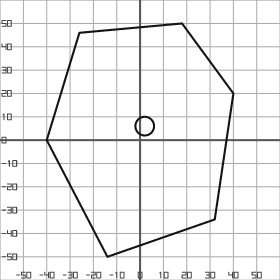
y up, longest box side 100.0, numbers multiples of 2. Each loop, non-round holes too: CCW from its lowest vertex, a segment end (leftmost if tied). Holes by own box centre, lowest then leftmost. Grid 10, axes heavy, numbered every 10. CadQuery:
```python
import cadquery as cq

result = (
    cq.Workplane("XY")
    .moveTo(-14.0, -50.0)
    .lineTo(32.0, -34.0)
    .lineTo(40.0, 20.0)
    .lineTo(18.0, 50.0)
    .lineTo(-26.0, 46.0)
    .lineTo(-40.0, 0.0)
    .close()
    .moveTo(2.0, 6.0)
    .circle(4.0)
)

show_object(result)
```